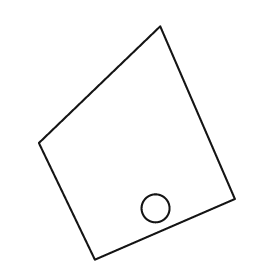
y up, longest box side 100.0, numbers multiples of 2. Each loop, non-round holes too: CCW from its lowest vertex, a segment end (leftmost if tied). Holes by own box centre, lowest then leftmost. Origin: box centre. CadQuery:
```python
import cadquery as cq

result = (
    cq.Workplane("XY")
    .moveTo(-18.0, -50.0)
    .lineTo(42.0, -24.0)
    .lineTo(10.0, 50.0)
    .lineTo(-42.0, 0.0)
    .close()
    .moveTo(8.0, -28.0)
    .circle(6.0)
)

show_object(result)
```